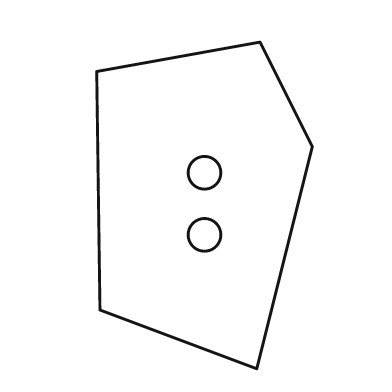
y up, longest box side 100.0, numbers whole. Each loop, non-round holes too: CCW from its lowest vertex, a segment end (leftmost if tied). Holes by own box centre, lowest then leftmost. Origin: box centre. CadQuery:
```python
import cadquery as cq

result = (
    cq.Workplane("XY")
    .moveTo(16.0, -50.0)
    .lineTo(33.0, 18.0)
    .lineTo(17.0, 50.0)
    .lineTo(-33.0, 41.0)
    .lineTo(-32.0, -32.0)
    .close()
    .moveTo(0.0, -9.0)
    .circle(5.0)
    .moveTo(0.0, 10.0)
    .circle(5.0)
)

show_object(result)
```